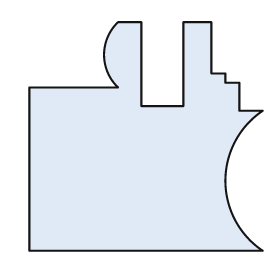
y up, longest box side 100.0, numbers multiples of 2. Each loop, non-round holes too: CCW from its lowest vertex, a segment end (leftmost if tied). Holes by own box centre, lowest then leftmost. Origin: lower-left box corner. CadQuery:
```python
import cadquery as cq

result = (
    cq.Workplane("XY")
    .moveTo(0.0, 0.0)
    .lineTo(100.0, 0.0)
    .threePointArc((84.0, 30.0), (100.0, 60.0))
    .lineTo(90.0, 60.0)
    .lineTo(90.0, 72.0)
    .lineTo(84.0, 72.0)
    .lineTo(84.0, 76.0)
    .lineTo(78.0, 76.0)
    .lineTo(78.0, 98.0)
    .lineTo(66.0, 98.0)
    .lineTo(66.0, 62.0)
    .lineTo(48.0, 62.0)
    .lineTo(48.0, 98.0)
    .lineTo(38.0, 98.0)
    .threePointArc((32.0, 84.0), (38.0, 70.0))
    .lineTo(0.0, 70.0)
    .close()
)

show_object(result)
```